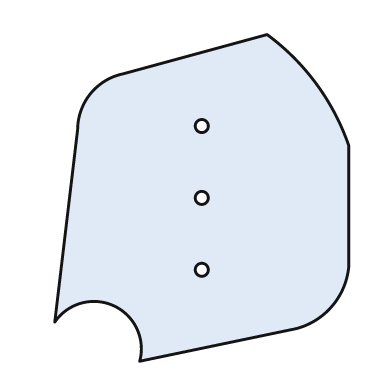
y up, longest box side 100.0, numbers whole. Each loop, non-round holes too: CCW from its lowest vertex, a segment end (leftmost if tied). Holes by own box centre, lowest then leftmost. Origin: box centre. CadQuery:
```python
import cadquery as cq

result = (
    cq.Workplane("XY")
    .moveTo(-19.0, -50.0)
    .lineTo(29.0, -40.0)
    .threePointArc((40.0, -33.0), (45.0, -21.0))
    .lineTo(45.0, 16.0)
    .threePointArc((35.0, 35.0), (20.0, 50.0))
    .lineTo(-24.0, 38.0)
    .threePointArc((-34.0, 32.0), (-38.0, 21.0))
    .lineTo(-45.0, -38.0)
    .threePointArc((-27.0, -33.0), (-19.0, -50.0))
    .close()
    .moveTo(0.0, -22.0)
    .circle(2.0)
    .moveTo(0.0, 0.0)
    .circle(2.0)
    .moveTo(0.0, 22.0)
    .circle(2.0)
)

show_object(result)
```